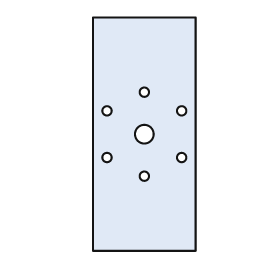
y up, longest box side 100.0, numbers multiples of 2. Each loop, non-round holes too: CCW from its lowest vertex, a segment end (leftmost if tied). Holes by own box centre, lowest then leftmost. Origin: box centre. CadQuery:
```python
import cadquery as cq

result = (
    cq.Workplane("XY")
    .moveTo(-22.0, -50.0)
    .lineTo(22.0, -50.0)
    .lineTo(22.0, 50.0)
    .lineTo(-22.0, 50.0)
    .close()
    .moveTo(0.0, -18.0)
    .circle(2.0)
    .moveTo(-16.0, -10.0)
    .circle(2.0)
    .moveTo(16.0, -10.0)
    .circle(2.0)
    .moveTo(0.0, 0.0)
    .circle(4.0)
    .moveTo(-16.0, 10.0)
    .circle(2.0)
    .moveTo(16.0, 10.0)
    .circle(2.0)
    .moveTo(0.0, 18.0)
    .circle(2.0)
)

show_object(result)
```